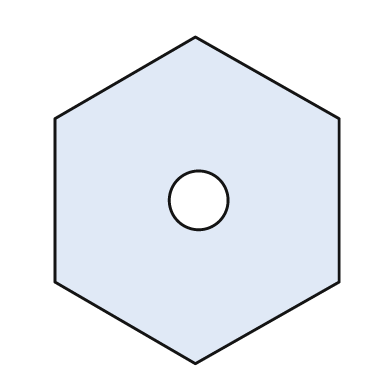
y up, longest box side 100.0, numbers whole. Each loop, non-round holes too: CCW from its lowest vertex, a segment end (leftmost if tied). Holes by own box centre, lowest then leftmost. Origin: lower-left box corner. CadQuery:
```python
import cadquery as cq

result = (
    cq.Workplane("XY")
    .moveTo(43.0, 0.0)
    .lineTo(87.0, 25.0)
    .lineTo(87.0, 75.0)
    .lineTo(43.0, 100.0)
    .lineTo(0.0, 75.0)
    .lineTo(0.0, 25.0)
    .close()
    .moveTo(44.0, 50.0)
    .circle(9.0)
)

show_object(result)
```